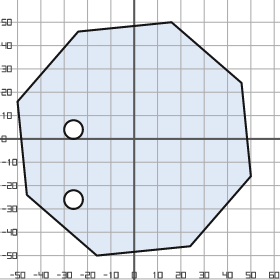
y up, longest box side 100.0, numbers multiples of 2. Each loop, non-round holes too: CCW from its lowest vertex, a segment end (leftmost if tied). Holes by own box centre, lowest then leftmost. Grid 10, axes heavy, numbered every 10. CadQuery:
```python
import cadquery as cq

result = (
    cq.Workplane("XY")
    .moveTo(-16.0, -50.0)
    .lineTo(24.0, -46.0)
    .lineTo(50.0, -16.0)
    .lineTo(46.0, 24.0)
    .lineTo(16.0, 50.0)
    .lineTo(-24.0, 46.0)
    .lineTo(-50.0, 16.0)
    .lineTo(-46.0, -24.0)
    .close()
    .moveTo(-26.0, -26.0)
    .circle(4.0)
    .moveTo(-26.0, 4.0)
    .circle(4.0)
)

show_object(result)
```